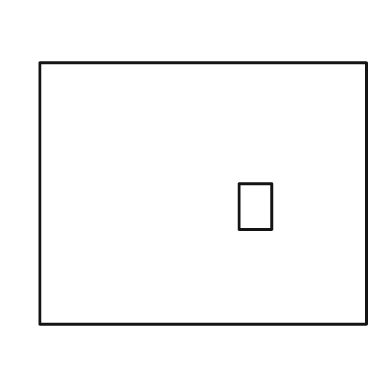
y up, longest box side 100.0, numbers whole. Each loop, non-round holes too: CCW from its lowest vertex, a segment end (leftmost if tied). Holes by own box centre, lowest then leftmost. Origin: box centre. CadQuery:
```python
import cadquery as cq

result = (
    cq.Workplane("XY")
    .moveTo(-50.0, -40.0)
    .lineTo(50.0, -40.0)
    .lineTo(50.0, 40.0)
    .lineTo(-50.0, 40.0)
    .close()
    .moveTo(11.0, -11.0)
    .lineTo(21.0, -11.0)
    .lineTo(21.0, 3.0)
    .lineTo(11.0, 3.0)
    .close()
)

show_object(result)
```